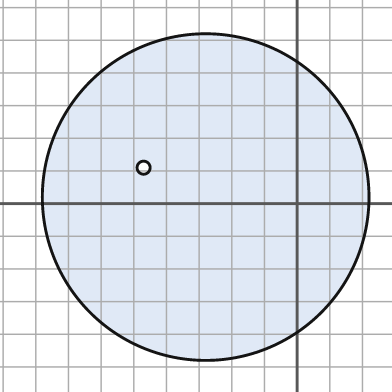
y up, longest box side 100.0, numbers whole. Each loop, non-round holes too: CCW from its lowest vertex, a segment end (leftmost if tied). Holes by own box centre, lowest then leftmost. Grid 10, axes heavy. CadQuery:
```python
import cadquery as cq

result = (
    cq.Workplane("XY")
    .moveTo(-28.0, 2.0)
    .circle(50.0)
    .moveTo(-47.0, 11.0)
    .circle(2.0)
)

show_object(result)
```